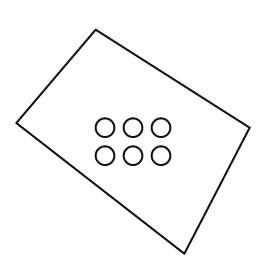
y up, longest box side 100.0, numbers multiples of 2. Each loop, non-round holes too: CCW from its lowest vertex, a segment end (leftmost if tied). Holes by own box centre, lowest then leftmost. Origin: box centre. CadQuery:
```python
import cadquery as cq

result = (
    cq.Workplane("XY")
    .moveTo(22.0, -48.0)
    .lineTo(50.0, 6.0)
    .lineTo(-16.0, 48.0)
    .lineTo(-50.0, 8.0)
    .close()
    .moveTo(-12.0, -6.0)
    .circle(4.0)
    .moveTo(0.0, -6.0)
    .circle(4.0)
    .moveTo(12.0, -6.0)
    .circle(4.0)
    .moveTo(-12.0, 6.0)
    .circle(4.0)
    .moveTo(0.0, 6.0)
    .circle(4.0)
    .moveTo(12.0, 6.0)
    .circle(4.0)
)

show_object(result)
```